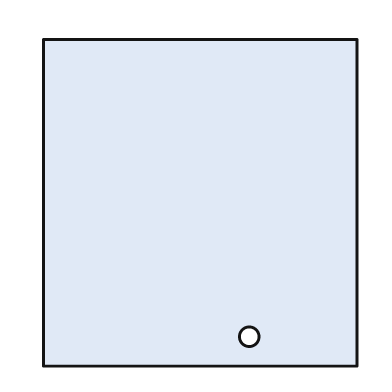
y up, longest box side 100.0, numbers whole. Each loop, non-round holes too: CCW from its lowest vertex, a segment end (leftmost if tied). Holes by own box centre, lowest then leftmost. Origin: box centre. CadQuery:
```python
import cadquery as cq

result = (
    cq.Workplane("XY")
    .moveTo(-48.0, -50.0)
    .lineTo(48.0, -50.0)
    .lineTo(48.0, 50.0)
    .lineTo(-48.0, 50.0)
    .close()
    .moveTo(15.0, -41.0)
    .circle(3.0)
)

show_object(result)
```